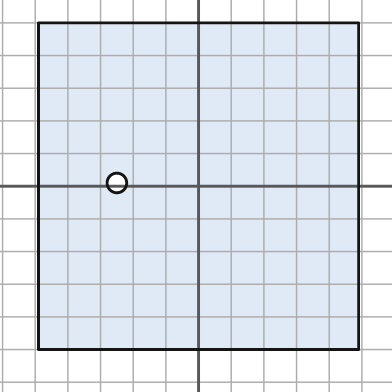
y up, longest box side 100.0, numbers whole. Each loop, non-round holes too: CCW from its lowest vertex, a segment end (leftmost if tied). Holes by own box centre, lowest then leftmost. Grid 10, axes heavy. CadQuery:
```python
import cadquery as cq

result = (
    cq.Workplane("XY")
    .moveTo(-49.0, -50.0)
    .lineTo(49.0, -50.0)
    .lineTo(49.0, 50.0)
    .lineTo(-49.0, 50.0)
    .close()
    .moveTo(-25.0, 1.0)
    .circle(3.0)
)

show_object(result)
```